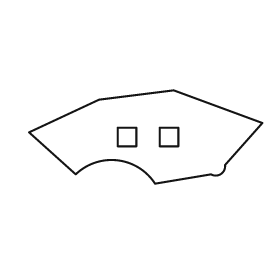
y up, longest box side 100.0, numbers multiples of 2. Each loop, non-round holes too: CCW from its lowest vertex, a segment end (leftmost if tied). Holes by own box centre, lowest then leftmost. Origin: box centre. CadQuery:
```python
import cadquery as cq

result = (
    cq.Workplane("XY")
    .moveTo(4.0, -20.0)
    .lineTo(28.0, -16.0)
    .threePointArc((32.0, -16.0), (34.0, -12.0))
    .lineTo(50.0, 6.0)
    .lineTo(12.0, 20.0)
    .lineTo(-20.0, 16.0)
    .lineTo(-50.0, 2.0)
    .lineTo(-30.0, -16.0)
    .threePointArc((-12.0, -10.0), (4.0, -20.0))
    .close()
    .moveTo(-12.0, -4.0)
    .lineTo(-4.0, -4.0)
    .lineTo(-4.0, 4.0)
    .lineTo(-12.0, 4.0)
    .close()
    .moveTo(6.0, -4.0)
    .lineTo(14.0, -4.0)
    .lineTo(14.0, 4.0)
    .lineTo(6.0, 4.0)
    .close()
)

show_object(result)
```